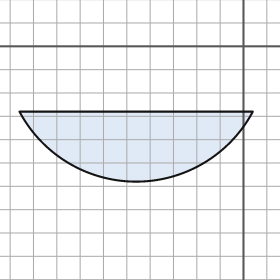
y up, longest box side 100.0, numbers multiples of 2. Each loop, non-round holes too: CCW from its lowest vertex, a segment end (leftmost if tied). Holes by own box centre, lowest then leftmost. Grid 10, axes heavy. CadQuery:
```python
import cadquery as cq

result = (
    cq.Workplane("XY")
    .moveTo(-96.0, -28.0)
    .threePointArc((-46.0, -58.0), (4.0, -28.0))
    .close()
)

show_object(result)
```